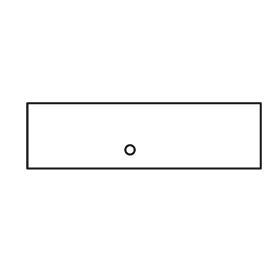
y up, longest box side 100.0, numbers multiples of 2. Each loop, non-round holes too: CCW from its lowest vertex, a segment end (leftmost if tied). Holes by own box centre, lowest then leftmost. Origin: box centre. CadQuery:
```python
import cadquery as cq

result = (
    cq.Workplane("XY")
    .moveTo(-50.0, -14.0)
    .lineTo(50.0, -14.0)
    .lineTo(50.0, 14.0)
    .lineTo(-50.0, 14.0)
    .close()
    .moveTo(-6.0, -6.0)
    .circle(2.0)
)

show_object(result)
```